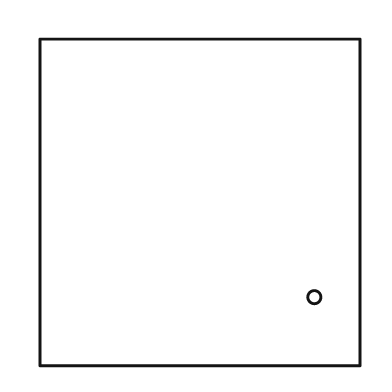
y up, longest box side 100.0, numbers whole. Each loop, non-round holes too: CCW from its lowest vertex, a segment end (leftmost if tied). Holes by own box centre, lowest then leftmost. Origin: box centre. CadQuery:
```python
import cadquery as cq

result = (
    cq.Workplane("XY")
    .moveTo(-49.0, -50.0)
    .lineTo(49.0, -50.0)
    .lineTo(49.0, 50.0)
    .lineTo(-49.0, 50.0)
    .close()
    .moveTo(35.0, -29.0)
    .circle(2.0)
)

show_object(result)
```